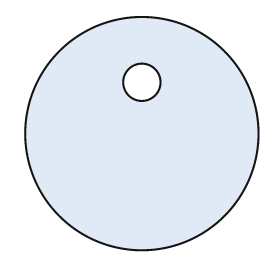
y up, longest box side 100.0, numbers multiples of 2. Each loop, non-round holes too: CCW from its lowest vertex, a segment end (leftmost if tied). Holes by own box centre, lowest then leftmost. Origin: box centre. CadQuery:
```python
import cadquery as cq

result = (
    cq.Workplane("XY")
    .moveTo(0.0, 0.0)
    .circle(50.0)
    .moveTo(0.0, 22.0)
    .circle(8.0)
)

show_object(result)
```